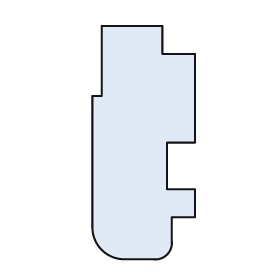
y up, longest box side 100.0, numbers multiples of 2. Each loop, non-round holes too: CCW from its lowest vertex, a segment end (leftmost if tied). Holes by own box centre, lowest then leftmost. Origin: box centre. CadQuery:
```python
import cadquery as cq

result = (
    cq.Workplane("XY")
    .moveTo(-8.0, -50.0)
    .lineTo(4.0, -50.0)
    .threePointArc((10.0, -48.0), (12.0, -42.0))
    .lineTo(12.0, -32.0)
    .lineTo(22.0, -32.0)
    .lineTo(22.0, -20.0)
    .lineTo(10.0, -20.0)
    .lineTo(10.0, 0.0)
    .lineTo(22.0, 0.0)
    .lineTo(22.0, 38.0)
    .lineTo(8.0, 38.0)
    .lineTo(8.0, 50.0)
    .lineTo(-18.0, 50.0)
    .lineTo(-18.0, 20.0)
    .lineTo(-22.0, 20.0)
    .lineTo(-22.0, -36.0)
    .threePointArc((-18.0, -46.0), (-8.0, -50.0))
    .close()
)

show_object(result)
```